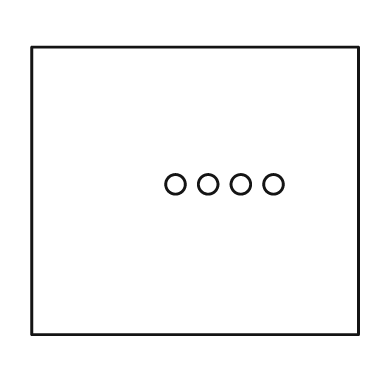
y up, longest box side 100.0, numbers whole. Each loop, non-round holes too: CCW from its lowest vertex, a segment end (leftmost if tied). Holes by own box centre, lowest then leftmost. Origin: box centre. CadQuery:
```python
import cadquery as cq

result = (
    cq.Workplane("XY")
    .moveTo(-50.0, -44.0)
    .lineTo(50.0, -44.0)
    .lineTo(50.0, 44.0)
    .lineTo(-50.0, 44.0)
    .close()
    .moveTo(-6.0, 2.0)
    .circle(3.0)
    .moveTo(4.0, 2.0)
    .circle(3.0)
    .moveTo(14.0, 2.0)
    .circle(3.0)
    .moveTo(24.0, 2.0)
    .circle(3.0)
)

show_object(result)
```